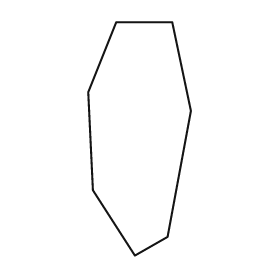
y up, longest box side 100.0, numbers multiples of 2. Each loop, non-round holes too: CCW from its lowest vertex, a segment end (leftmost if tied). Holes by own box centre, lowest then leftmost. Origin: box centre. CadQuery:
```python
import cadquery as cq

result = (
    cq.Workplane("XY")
    .moveTo(-2.0, -50.0)
    .lineTo(12.0, -42.0)
    .lineTo(22.0, 12.0)
    .lineTo(14.0, 50.0)
    .lineTo(-10.0, 50.0)
    .lineTo(-22.0, 20.0)
    .lineTo(-20.0, -22.0)
    .close()
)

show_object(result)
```